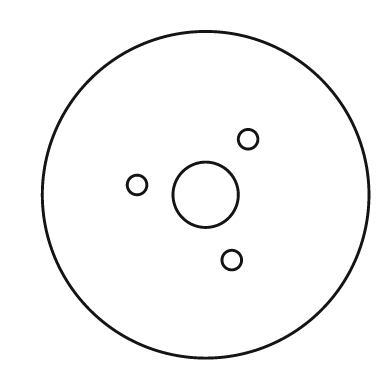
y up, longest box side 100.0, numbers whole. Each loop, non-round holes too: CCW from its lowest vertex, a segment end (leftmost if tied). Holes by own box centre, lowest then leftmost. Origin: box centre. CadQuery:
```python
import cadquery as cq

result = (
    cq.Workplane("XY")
    .moveTo(0.0, 0.0)
    .circle(50.0)
    .moveTo(8.0, -20.0)
    .circle(3.0)
    .moveTo(0.0, 0.0)
    .circle(10.0)
    .moveTo(-21.0, 3.0)
    .circle(3.0)
    .moveTo(13.0, 17.0)
    .circle(3.0)
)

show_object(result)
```